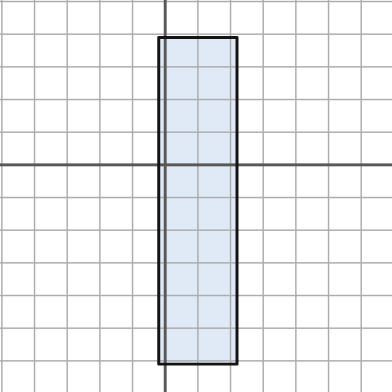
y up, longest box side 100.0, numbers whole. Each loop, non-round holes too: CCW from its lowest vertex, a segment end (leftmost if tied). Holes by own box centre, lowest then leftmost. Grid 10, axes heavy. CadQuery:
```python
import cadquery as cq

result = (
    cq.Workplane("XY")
    .moveTo(-2.0, -61.0)
    .lineTo(22.0, -61.0)
    .lineTo(22.0, 39.0)
    .lineTo(-2.0, 39.0)
    .close()
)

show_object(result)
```